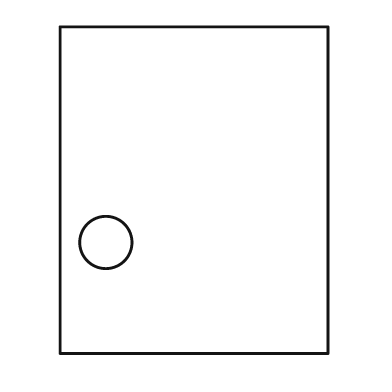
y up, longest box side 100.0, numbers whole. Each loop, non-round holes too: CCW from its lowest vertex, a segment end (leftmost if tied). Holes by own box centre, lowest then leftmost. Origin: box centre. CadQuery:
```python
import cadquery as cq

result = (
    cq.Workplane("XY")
    .moveTo(-41.0, -50.0)
    .lineTo(41.0, -50.0)
    .lineTo(41.0, 50.0)
    .lineTo(-41.0, 50.0)
    .close()
    .moveTo(-27.0, -16.0)
    .circle(8.0)
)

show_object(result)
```